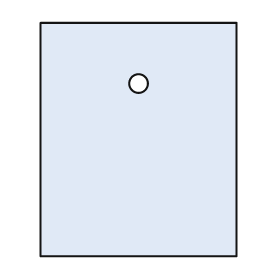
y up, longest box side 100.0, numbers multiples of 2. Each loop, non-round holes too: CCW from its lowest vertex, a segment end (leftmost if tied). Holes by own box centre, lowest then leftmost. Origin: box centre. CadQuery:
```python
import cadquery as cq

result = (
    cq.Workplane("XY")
    .moveTo(-42.0, -50.0)
    .lineTo(42.0, -50.0)
    .lineTo(42.0, 50.0)
    .lineTo(-42.0, 50.0)
    .close()
    .moveTo(0.0, 24.0)
    .circle(4.0)
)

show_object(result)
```